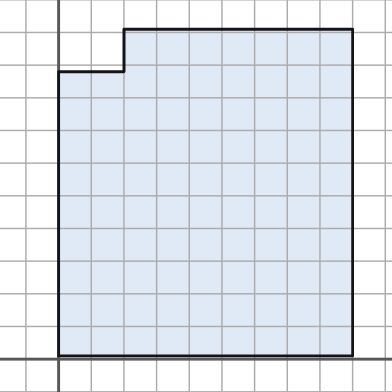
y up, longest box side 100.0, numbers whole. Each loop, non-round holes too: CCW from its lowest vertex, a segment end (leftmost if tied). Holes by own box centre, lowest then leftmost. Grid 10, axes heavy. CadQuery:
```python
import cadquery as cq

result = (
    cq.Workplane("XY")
    .moveTo(0.0, 1.0)
    .lineTo(90.0, 1.0)
    .lineTo(90.0, 101.0)
    .lineTo(20.0, 101.0)
    .lineTo(20.0, 88.0)
    .lineTo(0.0, 88.0)
    .close()
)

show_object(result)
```